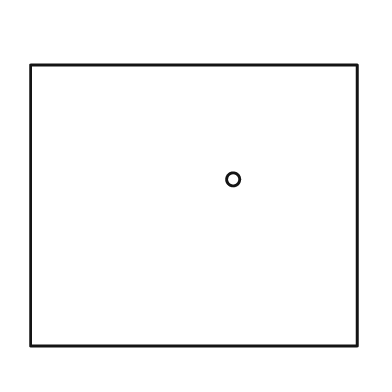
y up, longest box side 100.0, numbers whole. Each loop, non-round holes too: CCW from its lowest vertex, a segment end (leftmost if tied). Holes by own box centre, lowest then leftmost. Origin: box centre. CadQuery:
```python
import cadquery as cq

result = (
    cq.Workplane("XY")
    .moveTo(-50.0, -43.0)
    .lineTo(50.0, -43.0)
    .lineTo(50.0, 43.0)
    .lineTo(-50.0, 43.0)
    .close()
    .moveTo(12.0, 8.0)
    .circle(2.0)
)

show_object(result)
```